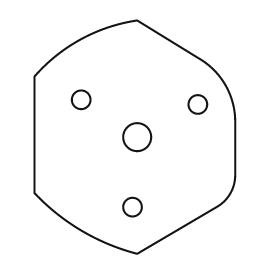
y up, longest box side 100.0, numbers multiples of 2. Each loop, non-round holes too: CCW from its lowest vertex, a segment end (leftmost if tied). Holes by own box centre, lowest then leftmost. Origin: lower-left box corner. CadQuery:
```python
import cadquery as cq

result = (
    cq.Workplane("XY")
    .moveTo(44.0, 0.0)
    .lineTo(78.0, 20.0)
    .threePointArc((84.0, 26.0), (86.0, 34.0))
    .lineTo(86.0, 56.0)
    .threePointArc((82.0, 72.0), (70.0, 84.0))
    .lineTo(44.0, 100.0)
    .threePointArc((20.0, 92.0), (0.0, 76.0))
    .lineTo(0.0, 26.0)
    .threePointArc((20.0, 10.0), (44.0, 0.0))
    .close()
    .moveTo(42.0, 20.0)
    .circle(4.0)
    .moveTo(44.0, 50.0)
    .circle(6.0)
    .moveTo(70.0, 64.0)
    .circle(4.0)
    .moveTo(20.0, 66.0)
    .circle(4.0)
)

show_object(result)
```